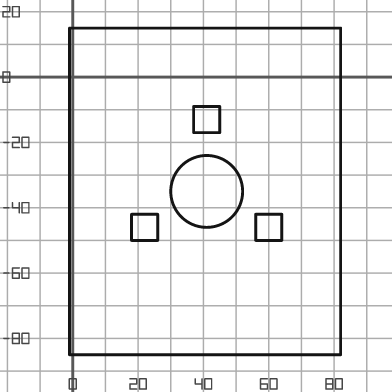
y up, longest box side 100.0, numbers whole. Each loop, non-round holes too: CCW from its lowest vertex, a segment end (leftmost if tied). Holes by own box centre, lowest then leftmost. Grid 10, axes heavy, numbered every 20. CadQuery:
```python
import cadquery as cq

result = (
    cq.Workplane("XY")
    .moveTo(-1.0, -85.0)
    .lineTo(82.0, -85.0)
    .lineTo(82.0, 15.0)
    .lineTo(-1.0, 15.0)
    .close()
    .moveTo(18.0, -50.0)
    .lineTo(26.0, -50.0)
    .lineTo(26.0, -42.0)
    .lineTo(18.0, -42.0)
    .close()
    .moveTo(56.0, -50.0)
    .lineTo(64.0, -50.0)
    .lineTo(64.0, -42.0)
    .lineTo(56.0, -42.0)
    .close()
    .moveTo(41.0, -35.0)
    .circle(11.0)
    .moveTo(37.0, -17.0)
    .lineTo(45.0, -17.0)
    .lineTo(45.0, -9.0)
    .lineTo(37.0, -9.0)
    .close()
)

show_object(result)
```